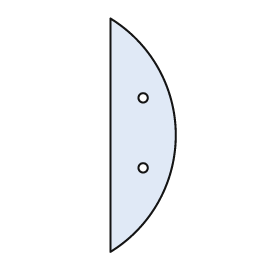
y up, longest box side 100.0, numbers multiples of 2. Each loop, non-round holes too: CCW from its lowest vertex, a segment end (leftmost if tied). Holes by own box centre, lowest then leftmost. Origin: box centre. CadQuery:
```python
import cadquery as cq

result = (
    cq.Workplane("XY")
    .moveTo(-14.0, -50.0)
    .threePointArc((14.0, 0.0), (-14.0, 50.0))
    .close()
    .moveTo(0.0, -14.0)
    .circle(2.0)
    .moveTo(0.0, 16.0)
    .circle(2.0)
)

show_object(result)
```